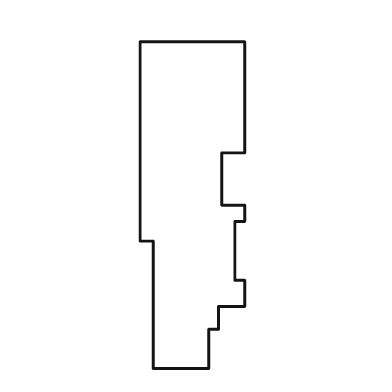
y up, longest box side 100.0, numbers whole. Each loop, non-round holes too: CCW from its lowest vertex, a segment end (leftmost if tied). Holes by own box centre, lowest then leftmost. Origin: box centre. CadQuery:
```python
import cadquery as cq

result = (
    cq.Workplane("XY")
    .moveTo(-12.0, -50.0)
    .lineTo(5.0, -50.0)
    .lineTo(5.0, -38.0)
    .lineTo(8.0, -38.0)
    .lineTo(8.0, -31.0)
    .lineTo(16.0, -31.0)
    .lineTo(16.0, -23.0)
    .lineTo(13.0, -23.0)
    .lineTo(13.0, -5.0)
    .lineTo(16.0, -5.0)
    .lineTo(16.0, 0.0)
    .lineTo(9.0, 0.0)
    .lineTo(9.0, 16.0)
    .lineTo(16.0, 16.0)
    .lineTo(16.0, 50.0)
    .lineTo(-16.0, 50.0)
    .lineTo(-16.0, -11.0)
    .lineTo(-12.0, -11.0)
    .close()
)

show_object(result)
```